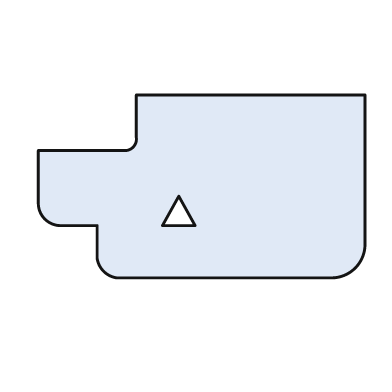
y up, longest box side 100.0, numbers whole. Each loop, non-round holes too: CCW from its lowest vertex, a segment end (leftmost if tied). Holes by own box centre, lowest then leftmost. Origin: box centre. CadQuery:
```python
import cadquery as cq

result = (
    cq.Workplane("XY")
    .moveTo(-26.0, -28.0)
    .lineTo(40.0, -28.0)
    .threePointArc((47.0, -25.0), (50.0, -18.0))
    .lineTo(50.0, 28.0)
    .lineTo(-20.0, 28.0)
    .lineTo(-20.0, 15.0)
    .threePointArc((-21.0, 12.0), (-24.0, 11.0))
    .lineTo(-50.0, 11.0)
    .lineTo(-50.0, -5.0)
    .threePointArc((-48.0, -10.0), (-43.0, -12.0))
    .lineTo(-32.0, -12.0)
    .lineTo(-32.0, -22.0)
    .threePointArc((-30.0, -26.0), (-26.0, -28.0))
    .close()
    .moveTo(-12.0, -12.0)
    .lineTo(-2.0, -12.0)
    .lineTo(-7.0, -3.0)
    .close()
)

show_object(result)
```